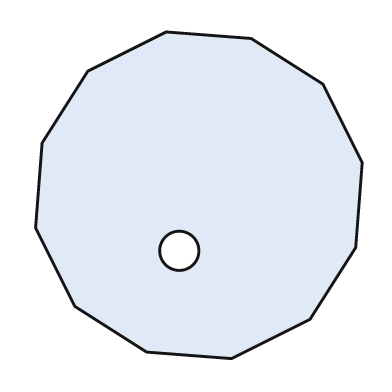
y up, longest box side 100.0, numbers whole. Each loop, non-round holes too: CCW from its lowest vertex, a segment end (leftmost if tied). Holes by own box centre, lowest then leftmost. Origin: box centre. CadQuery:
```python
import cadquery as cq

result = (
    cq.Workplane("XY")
    .moveTo(10.0, -50.0)
    .lineTo(34.0, -38.0)
    .lineTo(48.0, -16.0)
    .lineTo(50.0, 10.0)
    .lineTo(38.0, 34.0)
    .lineTo(16.0, 48.0)
    .lineTo(-10.0, 50.0)
    .lineTo(-34.0, 38.0)
    .lineTo(-48.0, 16.0)
    .lineTo(-50.0, -10.0)
    .lineTo(-38.0, -34.0)
    .lineTo(-16.0, -48.0)
    .close()
    .moveTo(-6.0, -17.0)
    .circle(6.0)
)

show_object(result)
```